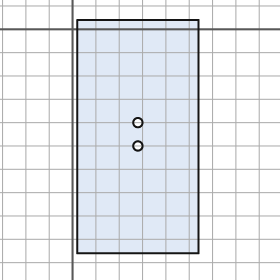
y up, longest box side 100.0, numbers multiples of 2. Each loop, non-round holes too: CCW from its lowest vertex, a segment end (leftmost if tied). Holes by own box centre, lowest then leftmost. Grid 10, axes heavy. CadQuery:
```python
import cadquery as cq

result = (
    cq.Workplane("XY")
    .moveTo(2.0, -96.0)
    .lineTo(54.0, -96.0)
    .lineTo(54.0, 4.0)
    .lineTo(2.0, 4.0)
    .close()
    .moveTo(28.0, -50.0)
    .circle(2.0)
    .moveTo(28.0, -40.0)
    .circle(2.0)
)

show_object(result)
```